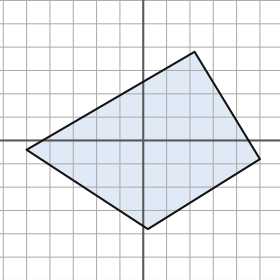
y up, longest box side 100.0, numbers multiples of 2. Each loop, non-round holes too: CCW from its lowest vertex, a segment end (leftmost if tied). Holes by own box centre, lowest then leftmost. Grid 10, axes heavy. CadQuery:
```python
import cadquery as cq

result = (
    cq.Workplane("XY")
    .moveTo(2.0, -38.0)
    .lineTo(50.0, -8.0)
    .lineTo(22.0, 38.0)
    .lineTo(-50.0, -4.0)
    .close()
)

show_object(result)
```